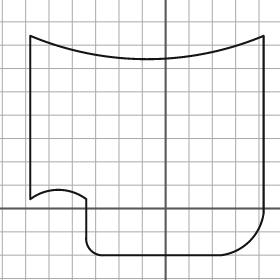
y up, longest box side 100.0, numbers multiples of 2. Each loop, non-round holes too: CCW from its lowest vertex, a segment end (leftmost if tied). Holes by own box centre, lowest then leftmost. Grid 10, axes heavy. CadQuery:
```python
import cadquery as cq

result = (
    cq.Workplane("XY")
    .moveTo(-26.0, -20.0)
    .lineTo(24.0, -20.0)
    .threePointArc((36.0, -14.0), (42.0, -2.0))
    .lineTo(42.0, 74.0)
    .threePointArc((-8.0, 64.0), (-58.0, 74.0))
    .lineTo(-58.0, 4.0)
    .threePointArc((-46.0, 8.0), (-34.0, 4.0))
    .lineTo(-34.0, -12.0)
    .threePointArc((-32.0, -18.0), (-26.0, -20.0))
    .close()
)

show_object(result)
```